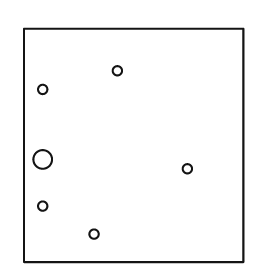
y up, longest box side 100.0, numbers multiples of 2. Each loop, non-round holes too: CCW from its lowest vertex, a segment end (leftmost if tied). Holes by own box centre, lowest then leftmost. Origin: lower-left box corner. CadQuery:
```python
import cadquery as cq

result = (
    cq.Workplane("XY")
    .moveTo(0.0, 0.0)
    .lineTo(94.0, 0.0)
    .lineTo(94.0, 100.0)
    .lineTo(0.0, 100.0)
    .close()
    .moveTo(30.0, 12.0)
    .circle(2.0)
    .moveTo(8.0, 24.0)
    .circle(2.0)
    .moveTo(70.0, 40.0)
    .circle(2.0)
    .moveTo(8.0, 44.0)
    .circle(4.0)
    .moveTo(8.0, 74.0)
    .circle(2.0)
    .moveTo(40.0, 82.0)
    .circle(2.0)
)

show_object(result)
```